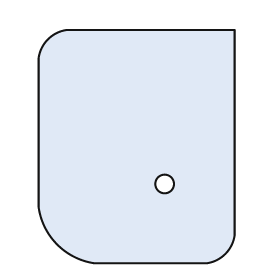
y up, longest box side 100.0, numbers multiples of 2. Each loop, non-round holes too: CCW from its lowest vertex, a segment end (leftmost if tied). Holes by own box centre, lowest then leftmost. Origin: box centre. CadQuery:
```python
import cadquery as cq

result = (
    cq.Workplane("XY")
    .moveTo(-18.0, -50.0)
    .lineTo(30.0, -50.0)
    .threePointArc((38.0, -46.0), (42.0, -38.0))
    .lineTo(42.0, 50.0)
    .lineTo(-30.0, 50.0)
    .threePointArc((-38.0, 46.0), (-42.0, 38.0))
    .lineTo(-42.0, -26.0)
    .threePointArc((-34.0, -42.0), (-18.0, -50.0))
    .close()
    .moveTo(12.0, -16.0)
    .circle(4.0)
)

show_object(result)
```